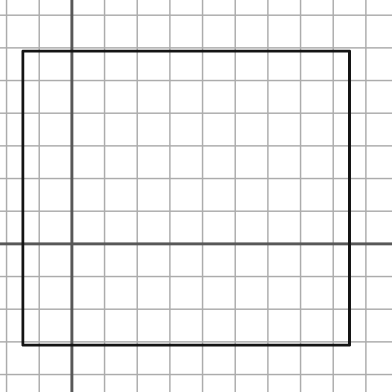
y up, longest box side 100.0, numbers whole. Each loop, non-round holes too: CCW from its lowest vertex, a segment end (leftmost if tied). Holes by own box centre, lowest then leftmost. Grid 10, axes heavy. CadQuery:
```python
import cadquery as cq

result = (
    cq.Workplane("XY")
    .moveTo(-15.0, -31.0)
    .lineTo(85.0, -31.0)
    .lineTo(85.0, 59.0)
    .lineTo(-15.0, 59.0)
    .close()
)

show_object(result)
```